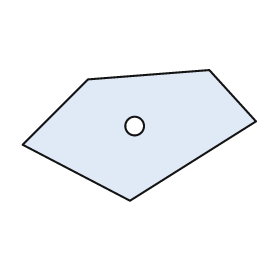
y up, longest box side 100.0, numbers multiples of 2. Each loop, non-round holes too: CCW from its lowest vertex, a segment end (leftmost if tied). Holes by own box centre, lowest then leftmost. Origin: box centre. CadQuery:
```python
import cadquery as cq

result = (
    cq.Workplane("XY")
    .moveTo(-4.0, -28.0)
    .lineTo(50.0, 6.0)
    .lineTo(30.0, 28.0)
    .lineTo(-22.0, 24.0)
    .lineTo(-50.0, -4.0)
    .close()
    .moveTo(-2.0, 4.0)
    .circle(4.0)
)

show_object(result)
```